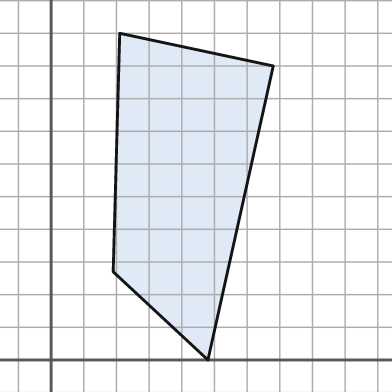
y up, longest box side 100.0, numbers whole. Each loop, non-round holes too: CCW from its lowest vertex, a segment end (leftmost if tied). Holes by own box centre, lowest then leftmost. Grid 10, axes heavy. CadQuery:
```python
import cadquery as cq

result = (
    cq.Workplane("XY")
    .moveTo(48.0, 0.0)
    .lineTo(68.0, 90.0)
    .lineTo(21.0, 100.0)
    .lineTo(19.0, 27.0)
    .close()
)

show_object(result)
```